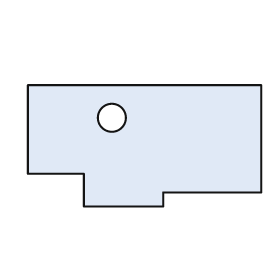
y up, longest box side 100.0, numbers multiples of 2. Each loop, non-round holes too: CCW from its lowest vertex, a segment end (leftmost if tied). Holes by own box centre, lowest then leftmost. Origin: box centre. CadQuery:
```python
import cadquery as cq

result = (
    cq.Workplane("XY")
    .moveTo(-26.0, -26.0)
    .lineTo(8.0, -26.0)
    .lineTo(8.0, -20.0)
    .lineTo(50.0, -20.0)
    .lineTo(50.0, 26.0)
    .lineTo(-50.0, 26.0)
    .lineTo(-50.0, -12.0)
    .lineTo(-26.0, -12.0)
    .close()
    .moveTo(-14.0, 12.0)
    .circle(6.0)
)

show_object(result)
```